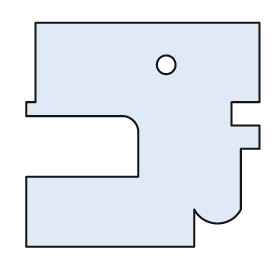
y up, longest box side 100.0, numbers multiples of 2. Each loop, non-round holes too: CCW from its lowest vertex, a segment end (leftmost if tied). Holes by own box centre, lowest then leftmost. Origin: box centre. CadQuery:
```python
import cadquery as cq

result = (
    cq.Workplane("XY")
    .moveTo(-50.0, -48.0)
    .lineTo(22.0, -48.0)
    .lineTo(22.0, -32.0)
    .threePointArc((32.0, -38.0), (42.0, -32.0))
    .lineTo(42.0, -6.0)
    .lineTo(50.0, -6.0)
    .lineTo(50.0, 4.0)
    .lineTo(38.0, 4.0)
    .lineTo(38.0, 14.0)
    .lineTo(50.0, 14.0)
    .lineTo(50.0, 48.0)
    .lineTo(-46.0, 48.0)
    .lineTo(-46.0, 14.0)
    .lineTo(-50.0, 14.0)
    .lineTo(-50.0, 8.0)
    .lineTo(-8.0, 8.0)
    .threePointArc((-4.0, 6.0), (-2.0, 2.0))
    .lineTo(-2.0, -18.0)
    .lineTo(-50.0, -18.0)
    .close()
    .moveTo(10.0, 30.0)
    .circle(4.0)
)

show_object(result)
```